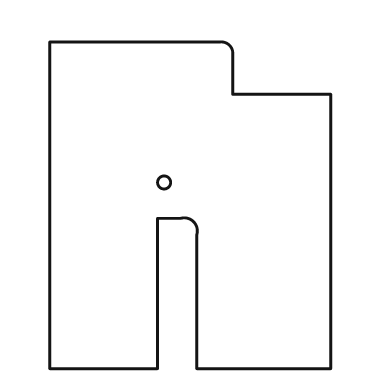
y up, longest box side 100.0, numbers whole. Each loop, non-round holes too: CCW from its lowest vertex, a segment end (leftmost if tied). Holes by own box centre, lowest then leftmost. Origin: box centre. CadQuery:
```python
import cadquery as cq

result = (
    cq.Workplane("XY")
    .moveTo(-43.0, -50.0)
    .lineTo(-10.0, -50.0)
    .lineTo(-10.0, -4.0)
    .lineTo(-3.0, -4.0)
    .threePointArc((1.0, -5.0), (2.0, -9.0))
    .lineTo(2.0, -50.0)
    .lineTo(43.0, -50.0)
    .lineTo(43.0, 34.0)
    .lineTo(13.0, 34.0)
    .lineTo(13.0, 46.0)
    .threePointArc((12.0, 49.0), (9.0, 50.0))
    .lineTo(-43.0, 50.0)
    .close()
    .moveTo(-8.0, 7.0)
    .circle(2.0)
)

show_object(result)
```